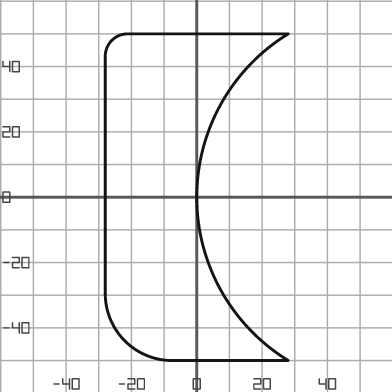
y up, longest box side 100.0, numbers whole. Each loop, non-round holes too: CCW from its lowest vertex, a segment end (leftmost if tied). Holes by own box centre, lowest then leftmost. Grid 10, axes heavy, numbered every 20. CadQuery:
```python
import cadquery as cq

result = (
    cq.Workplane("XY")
    .moveTo(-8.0, -50.0)
    .lineTo(28.0, -50.0)
    .threePointArc((0.0, 0.0), (28.0, 50.0))
    .lineTo(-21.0, 50.0)
    .threePointArc((-26.0, 48.0), (-28.0, 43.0))
    .lineTo(-28.0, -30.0)
    .threePointArc((-22.0, -44.0), (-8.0, -50.0))
    .close()
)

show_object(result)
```